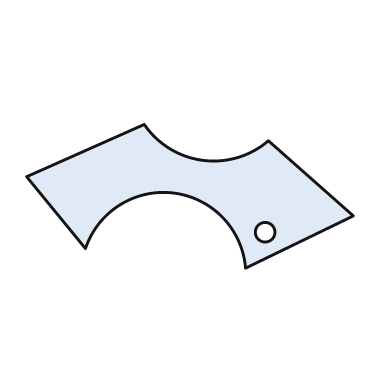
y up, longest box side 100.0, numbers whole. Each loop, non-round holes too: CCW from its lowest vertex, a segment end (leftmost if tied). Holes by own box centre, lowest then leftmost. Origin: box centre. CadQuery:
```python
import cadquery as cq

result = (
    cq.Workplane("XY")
    .moveTo(17.0, -22.0)
    .lineTo(50.0, -6.0)
    .lineTo(24.0, 17.0)
    .threePointArc((4.0, 11.0), (-14.0, 22.0))
    .lineTo(-50.0, 6.0)
    .lineTo(-32.0, -16.0)
    .threePointArc((-5.0, 1.0), (17.0, -22.0))
    .close()
    .moveTo(23.0, -11.0)
    .circle(3.0)
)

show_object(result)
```